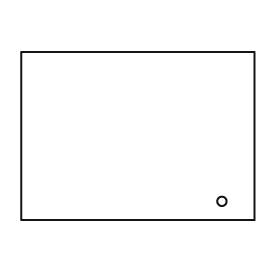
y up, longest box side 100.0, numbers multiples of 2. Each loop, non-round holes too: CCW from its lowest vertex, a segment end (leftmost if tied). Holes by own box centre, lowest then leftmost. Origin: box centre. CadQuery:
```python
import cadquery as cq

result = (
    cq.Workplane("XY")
    .moveTo(-50.0, -36.0)
    .lineTo(50.0, -36.0)
    .lineTo(50.0, 36.0)
    .lineTo(-50.0, 36.0)
    .close()
    .moveTo(36.0, -28.0)
    .circle(2.0)
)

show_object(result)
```